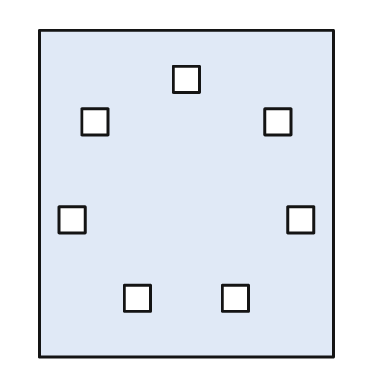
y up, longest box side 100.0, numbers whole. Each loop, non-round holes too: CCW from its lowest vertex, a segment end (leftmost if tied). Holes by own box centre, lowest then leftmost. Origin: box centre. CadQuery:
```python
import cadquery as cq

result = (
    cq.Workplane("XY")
    .moveTo(-45.0, -50.0)
    .lineTo(45.0, -50.0)
    .lineTo(45.0, 50.0)
    .lineTo(-45.0, 50.0)
    .close()
    .moveTo(-19.0, -36.0)
    .lineTo(-11.0, -36.0)
    .lineTo(-11.0, -28.0)
    .lineTo(-19.0, -28.0)
    .close()
    .moveTo(11.0, -36.0)
    .lineTo(19.0, -36.0)
    .lineTo(19.0, -28.0)
    .lineTo(11.0, -28.0)
    .close()
    .moveTo(-39.0, -12.0)
    .lineTo(-31.0, -12.0)
    .lineTo(-31.0, -4.0)
    .lineTo(-39.0, -4.0)
    .close()
    .moveTo(31.0, -12.0)
    .lineTo(39.0, -12.0)
    .lineTo(39.0, -4.0)
    .lineTo(31.0, -4.0)
    .close()
    .moveTo(-32.0, 18.0)
    .lineTo(-24.0, 18.0)
    .lineTo(-24.0, 26.0)
    .lineTo(-32.0, 26.0)
    .close()
    .moveTo(24.0, 18.0)
    .lineTo(32.0, 18.0)
    .lineTo(32.0, 26.0)
    .lineTo(24.0, 26.0)
    .close()
    .moveTo(-4.0, 31.0)
    .lineTo(4.0, 31.0)
    .lineTo(4.0, 39.0)
    .lineTo(-4.0, 39.0)
    .close()
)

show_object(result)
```